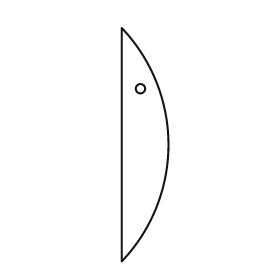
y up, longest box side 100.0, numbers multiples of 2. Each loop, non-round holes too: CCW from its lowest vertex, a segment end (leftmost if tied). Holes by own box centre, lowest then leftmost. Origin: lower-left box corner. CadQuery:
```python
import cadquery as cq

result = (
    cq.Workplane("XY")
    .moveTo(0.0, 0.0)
    .threePointArc((20.0, 50.0), (0.0, 100.0))
    .close()
    .moveTo(8.0, 74.0)
    .circle(2.0)
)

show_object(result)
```